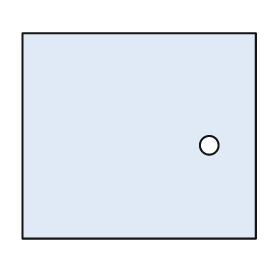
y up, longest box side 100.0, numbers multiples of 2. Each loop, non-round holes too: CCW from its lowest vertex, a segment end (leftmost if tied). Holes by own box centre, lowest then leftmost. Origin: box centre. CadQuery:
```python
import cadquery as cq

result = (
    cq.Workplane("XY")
    .moveTo(-50.0, -44.0)
    .lineTo(50.0, -44.0)
    .lineTo(50.0, 44.0)
    .lineTo(-50.0, 44.0)
    .close()
    .moveTo(30.0, -4.0)
    .circle(4.0)
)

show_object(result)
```